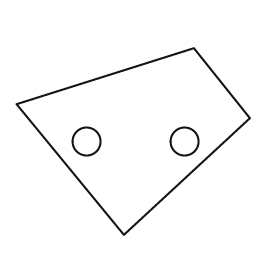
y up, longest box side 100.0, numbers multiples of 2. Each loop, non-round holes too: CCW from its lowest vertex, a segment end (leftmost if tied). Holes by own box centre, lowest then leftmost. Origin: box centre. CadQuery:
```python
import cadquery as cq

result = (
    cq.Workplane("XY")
    .moveTo(-4.0, -40.0)
    .lineTo(50.0, 10.0)
    .lineTo(26.0, 40.0)
    .lineTo(-50.0, 16.0)
    .close()
    .moveTo(-20.0, 0.0)
    .circle(6.0)
    .moveTo(22.0, 0.0)
    .circle(6.0)
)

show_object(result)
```